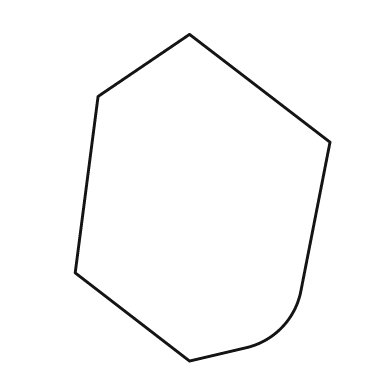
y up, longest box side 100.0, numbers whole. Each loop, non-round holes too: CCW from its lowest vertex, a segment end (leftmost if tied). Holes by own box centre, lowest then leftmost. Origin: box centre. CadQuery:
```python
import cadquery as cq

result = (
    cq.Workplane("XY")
    .moveTo(-4.0, -50.0)
    .lineTo(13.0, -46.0)
    .threePointArc((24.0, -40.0), (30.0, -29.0))
    .lineTo(39.0, 17.0)
    .lineTo(-4.0, 50.0)
    .lineTo(-32.0, 31.0)
    .lineTo(-39.0, -23.0)
    .close()
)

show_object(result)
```